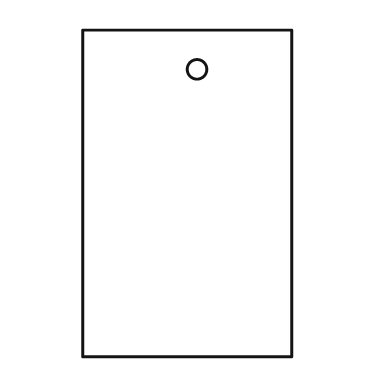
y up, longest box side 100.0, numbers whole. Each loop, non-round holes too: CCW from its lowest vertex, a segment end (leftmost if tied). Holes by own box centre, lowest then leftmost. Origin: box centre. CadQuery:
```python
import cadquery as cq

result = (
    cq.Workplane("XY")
    .moveTo(-32.0, -50.0)
    .lineTo(32.0, -50.0)
    .lineTo(32.0, 50.0)
    .lineTo(-32.0, 50.0)
    .close()
    .moveTo(3.0, 38.0)
    .circle(3.0)
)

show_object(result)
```